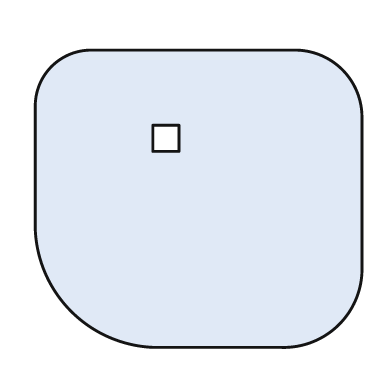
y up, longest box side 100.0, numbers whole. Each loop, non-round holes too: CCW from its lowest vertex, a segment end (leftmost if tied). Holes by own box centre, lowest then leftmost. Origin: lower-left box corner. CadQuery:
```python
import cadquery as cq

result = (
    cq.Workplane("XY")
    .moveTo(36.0, 0.0)
    .lineTo(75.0, 0.0)
    .threePointArc((93.0, 7.0), (100.0, 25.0))
    .lineTo(100.0, 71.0)
    .threePointArc((94.0, 85.0), (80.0, 91.0))
    .lineTo(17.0, 91.0)
    .threePointArc((5.0, 86.0), (0.0, 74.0))
    .lineTo(0.0, 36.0)
    .threePointArc((11.0, 11.0), (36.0, 0.0))
    .close()
    .moveTo(36.0, 60.0)
    .lineTo(44.0, 60.0)
    .lineTo(44.0, 68.0)
    .lineTo(36.0, 68.0)
    .close()
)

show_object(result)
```